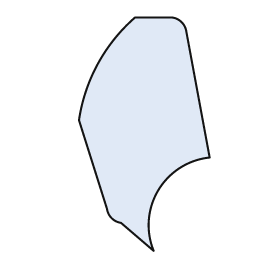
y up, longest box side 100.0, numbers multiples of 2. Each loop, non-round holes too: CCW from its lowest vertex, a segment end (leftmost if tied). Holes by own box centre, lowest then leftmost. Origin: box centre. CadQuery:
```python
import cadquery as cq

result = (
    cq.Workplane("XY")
    .moveTo(4.0, -50.0)
    .threePointArc((6.0, -24.0), (28.0, -10.0))
    .lineTo(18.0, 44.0)
    .threePointArc((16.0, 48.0), (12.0, 50.0))
    .lineTo(-4.0, 50.0)
    .threePointArc((-20.0, 30.0), (-28.0, 6.0))
    .lineTo(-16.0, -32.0)
    .threePointArc((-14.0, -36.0), (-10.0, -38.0))
    .close()
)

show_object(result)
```